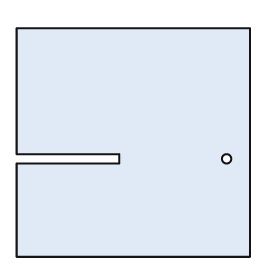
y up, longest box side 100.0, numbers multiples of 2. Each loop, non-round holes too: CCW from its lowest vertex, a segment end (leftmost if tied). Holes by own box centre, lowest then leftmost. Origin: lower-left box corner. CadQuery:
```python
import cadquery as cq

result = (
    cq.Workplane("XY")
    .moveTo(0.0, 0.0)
    .lineTo(100.0, 0.0)
    .lineTo(100.0, 98.0)
    .lineTo(0.0, 98.0)
    .lineTo(0.0, 44.0)
    .lineTo(44.0, 44.0)
    .lineTo(44.0, 40.0)
    .lineTo(0.0, 40.0)
    .close()
    .moveTo(90.0, 42.0)
    .circle(2.0)
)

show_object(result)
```